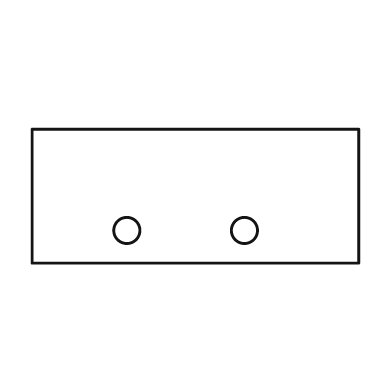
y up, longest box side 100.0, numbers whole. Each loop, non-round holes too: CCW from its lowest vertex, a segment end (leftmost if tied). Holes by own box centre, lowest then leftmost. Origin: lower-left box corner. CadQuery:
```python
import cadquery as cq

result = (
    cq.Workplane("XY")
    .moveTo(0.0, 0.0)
    .lineTo(100.0, 0.0)
    .lineTo(100.0, 41.0)
    .lineTo(0.0, 41.0)
    .close()
    .moveTo(29.0, 10.0)
    .circle(4.0)
    .moveTo(65.0, 10.0)
    .circle(4.0)
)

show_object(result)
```